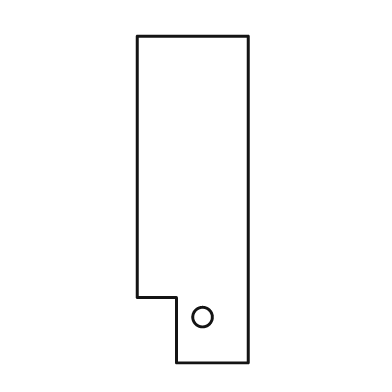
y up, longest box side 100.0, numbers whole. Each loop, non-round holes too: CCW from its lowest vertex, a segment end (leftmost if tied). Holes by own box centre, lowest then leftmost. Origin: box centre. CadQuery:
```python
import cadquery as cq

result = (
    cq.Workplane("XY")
    .moveTo(-5.0, -50.0)
    .lineTo(17.0, -50.0)
    .lineTo(17.0, 50.0)
    .lineTo(-17.0, 50.0)
    .lineTo(-17.0, -30.0)
    .lineTo(-5.0, -30.0)
    .close()
    .moveTo(3.0, -36.0)
    .circle(3.0)
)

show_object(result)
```